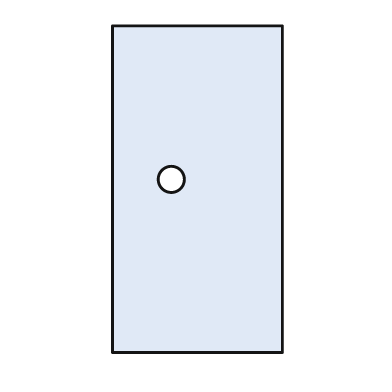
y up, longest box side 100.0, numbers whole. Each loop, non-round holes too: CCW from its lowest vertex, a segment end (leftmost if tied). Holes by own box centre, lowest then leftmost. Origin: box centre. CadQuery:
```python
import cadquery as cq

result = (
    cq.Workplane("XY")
    .moveTo(-26.0, -50.0)
    .lineTo(26.0, -50.0)
    .lineTo(26.0, 50.0)
    .lineTo(-26.0, 50.0)
    .close()
    .moveTo(-8.0, 3.0)
    .circle(4.0)
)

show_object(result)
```